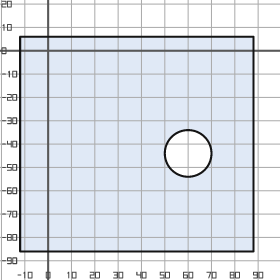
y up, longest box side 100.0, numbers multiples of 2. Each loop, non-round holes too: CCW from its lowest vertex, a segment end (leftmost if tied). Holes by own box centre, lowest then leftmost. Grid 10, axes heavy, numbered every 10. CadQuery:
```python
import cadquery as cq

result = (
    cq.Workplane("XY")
    .moveTo(-12.0, -86.0)
    .lineTo(88.0, -86.0)
    .lineTo(88.0, 6.0)
    .lineTo(-12.0, 6.0)
    .close()
    .moveTo(60.0, -44.0)
    .circle(10.0)
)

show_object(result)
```